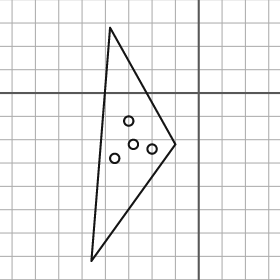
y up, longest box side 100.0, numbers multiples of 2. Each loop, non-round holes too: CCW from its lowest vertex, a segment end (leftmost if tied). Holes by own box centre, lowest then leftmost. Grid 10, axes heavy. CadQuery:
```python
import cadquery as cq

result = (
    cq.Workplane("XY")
    .moveTo(-46.0, -72.0)
    .lineTo(-10.0, -22.0)
    .lineTo(-38.0, 28.0)
    .close()
    .moveTo(-36.0, -28.0)
    .circle(2.0)
    .moveTo(-20.0, -24.0)
    .circle(2.0)
    .moveTo(-28.0, -22.0)
    .circle(2.0)
    .moveTo(-30.0, -12.0)
    .circle(2.0)
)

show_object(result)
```